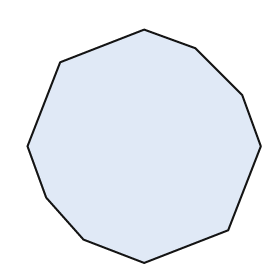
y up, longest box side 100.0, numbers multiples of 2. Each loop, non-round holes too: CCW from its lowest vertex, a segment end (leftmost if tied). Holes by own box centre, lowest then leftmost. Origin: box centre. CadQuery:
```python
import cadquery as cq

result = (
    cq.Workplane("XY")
    .moveTo(0.0, -50.0)
    .lineTo(36.0, -36.0)
    .lineTo(50.0, 0.0)
    .lineTo(42.0, 22.0)
    .lineTo(22.0, 42.0)
    .lineTo(0.0, 50.0)
    .lineTo(-36.0, 36.0)
    .lineTo(-50.0, 0.0)
    .lineTo(-42.0, -22.0)
    .lineTo(-26.0, -40.0)
    .close()
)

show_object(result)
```